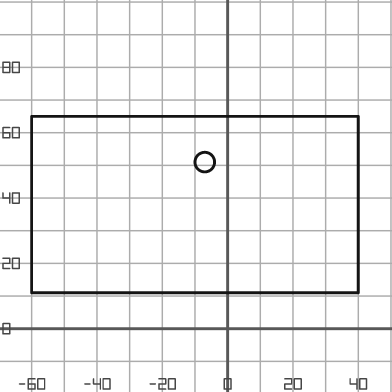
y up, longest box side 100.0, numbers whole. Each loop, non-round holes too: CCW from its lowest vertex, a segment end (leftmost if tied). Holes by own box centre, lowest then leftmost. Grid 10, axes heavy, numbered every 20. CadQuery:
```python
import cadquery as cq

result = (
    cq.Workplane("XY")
    .moveTo(-60.0, 11.0)
    .lineTo(40.0, 11.0)
    .lineTo(40.0, 65.0)
    .lineTo(-60.0, 65.0)
    .close()
    .moveTo(-7.0, 51.0)
    .circle(3.0)
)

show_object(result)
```